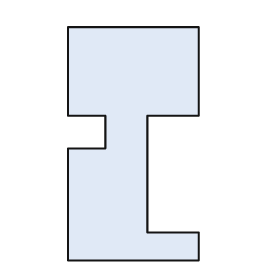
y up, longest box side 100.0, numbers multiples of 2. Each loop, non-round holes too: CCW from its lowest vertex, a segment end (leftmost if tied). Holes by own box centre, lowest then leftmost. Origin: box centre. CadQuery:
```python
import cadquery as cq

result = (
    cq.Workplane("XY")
    .moveTo(-28.0, -50.0)
    .lineTo(28.0, -50.0)
    .lineTo(28.0, -38.0)
    .lineTo(6.0, -38.0)
    .lineTo(6.0, 12.0)
    .lineTo(28.0, 12.0)
    .lineTo(28.0, 50.0)
    .lineTo(-28.0, 50.0)
    .lineTo(-28.0, 12.0)
    .lineTo(-12.0, 12.0)
    .lineTo(-12.0, -2.0)
    .lineTo(-28.0, -2.0)
    .close()
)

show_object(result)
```